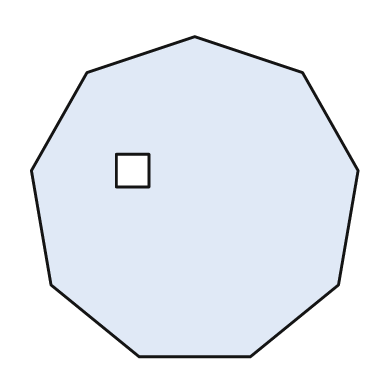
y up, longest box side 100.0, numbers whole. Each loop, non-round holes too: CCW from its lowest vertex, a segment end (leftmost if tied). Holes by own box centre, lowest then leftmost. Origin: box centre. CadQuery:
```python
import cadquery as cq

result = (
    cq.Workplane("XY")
    .moveTo(-17.0, -49.0)
    .lineTo(17.0, -49.0)
    .lineTo(44.0, -27.0)
    .lineTo(50.0, 8.0)
    .lineTo(33.0, 38.0)
    .lineTo(0.0, 49.0)
    .lineTo(-33.0, 38.0)
    .lineTo(-50.0, 8.0)
    .lineTo(-44.0, -27.0)
    .close()
    .moveTo(-24.0, 3.0)
    .lineTo(-14.0, 3.0)
    .lineTo(-14.0, 13.0)
    .lineTo(-24.0, 13.0)
    .close()
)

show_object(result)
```